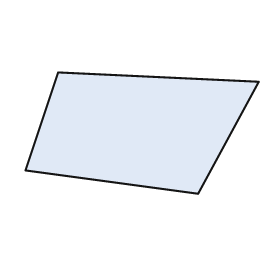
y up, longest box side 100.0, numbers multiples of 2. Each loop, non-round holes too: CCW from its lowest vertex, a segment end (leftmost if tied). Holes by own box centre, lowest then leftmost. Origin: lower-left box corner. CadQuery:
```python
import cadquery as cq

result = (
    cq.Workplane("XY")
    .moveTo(74.0, 0.0)
    .lineTo(100.0, 48.0)
    .lineTo(14.0, 52.0)
    .lineTo(0.0, 10.0)
    .close()
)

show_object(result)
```